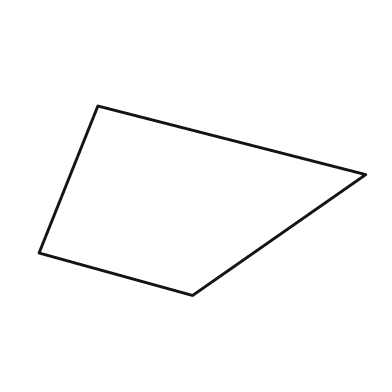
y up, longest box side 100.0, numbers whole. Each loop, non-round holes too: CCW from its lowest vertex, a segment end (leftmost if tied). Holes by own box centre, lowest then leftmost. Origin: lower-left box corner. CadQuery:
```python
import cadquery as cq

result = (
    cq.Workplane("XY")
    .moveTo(47.0, 0.0)
    .lineTo(100.0, 37.0)
    .lineTo(18.0, 58.0)
    .lineTo(0.0, 13.0)
    .close()
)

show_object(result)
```